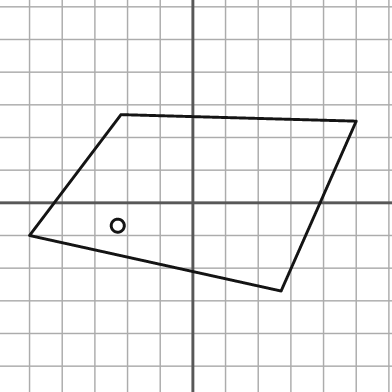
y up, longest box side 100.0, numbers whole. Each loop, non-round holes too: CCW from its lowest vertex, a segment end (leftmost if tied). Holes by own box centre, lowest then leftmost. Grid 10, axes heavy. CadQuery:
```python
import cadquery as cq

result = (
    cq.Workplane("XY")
    .moveTo(27.0, -27.0)
    .lineTo(50.0, 25.0)
    .lineTo(-22.0, 27.0)
    .lineTo(-50.0, -10.0)
    .close()
    .moveTo(-23.0, -7.0)
    .circle(2.0)
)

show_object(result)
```